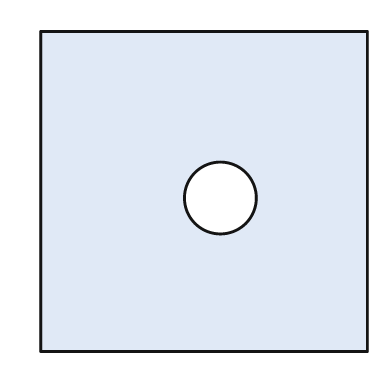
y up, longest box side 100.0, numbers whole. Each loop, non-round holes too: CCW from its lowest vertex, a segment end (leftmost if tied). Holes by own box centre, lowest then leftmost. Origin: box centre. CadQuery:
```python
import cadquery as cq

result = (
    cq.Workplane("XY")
    .moveTo(-50.0, -49.0)
    .lineTo(50.0, -49.0)
    .lineTo(50.0, 49.0)
    .lineTo(-50.0, 49.0)
    .close()
    .moveTo(5.0, -2.0)
    .circle(11.0)
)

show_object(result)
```